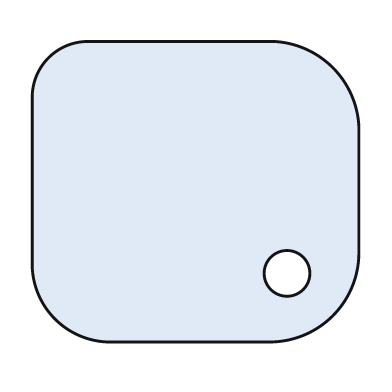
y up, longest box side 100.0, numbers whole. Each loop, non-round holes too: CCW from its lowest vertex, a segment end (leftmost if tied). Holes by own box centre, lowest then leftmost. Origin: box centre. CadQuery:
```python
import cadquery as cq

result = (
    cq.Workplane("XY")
    .moveTo(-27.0, -46.0)
    .lineTo(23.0, -46.0)
    .threePointArc((42.0, -38.0), (50.0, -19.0))
    .lineTo(50.0, 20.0)
    .threePointArc((42.0, 38.0), (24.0, 46.0))
    .lineTo(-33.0, 46.0)
    .threePointArc((-45.0, 41.0), (-50.0, 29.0))
    .lineTo(-50.0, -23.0)
    .threePointArc((-43.0, -39.0), (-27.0, -46.0))
    .close()
    .moveTo(28.0, -25.0)
    .circle(7.0)
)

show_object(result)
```